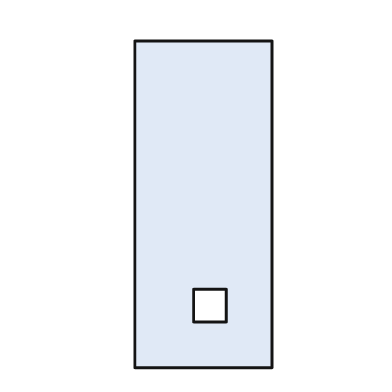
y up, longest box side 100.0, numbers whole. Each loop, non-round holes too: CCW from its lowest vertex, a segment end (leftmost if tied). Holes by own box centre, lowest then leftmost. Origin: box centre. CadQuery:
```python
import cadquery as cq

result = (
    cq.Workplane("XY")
    .moveTo(-21.0, -50.0)
    .lineTo(21.0, -50.0)
    .lineTo(21.0, 50.0)
    .lineTo(-21.0, 50.0)
    .close()
    .moveTo(-3.0, -36.0)
    .lineTo(7.0, -36.0)
    .lineTo(7.0, -26.0)
    .lineTo(-3.0, -26.0)
    .close()
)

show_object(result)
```